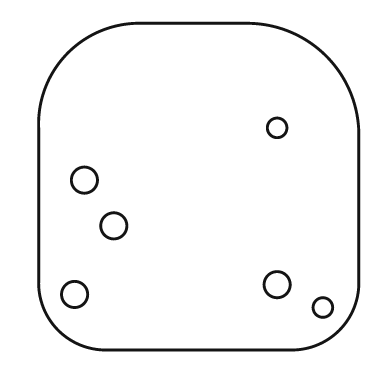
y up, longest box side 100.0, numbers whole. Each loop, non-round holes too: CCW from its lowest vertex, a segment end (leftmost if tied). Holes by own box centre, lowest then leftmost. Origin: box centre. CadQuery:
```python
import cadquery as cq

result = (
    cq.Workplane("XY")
    .moveTo(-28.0, -50.0)
    .lineTo(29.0, -50.0)
    .threePointArc((43.0, -44.0), (49.0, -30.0))
    .lineTo(49.0, 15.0)
    .threePointArc((39.0, 40.0), (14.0, 50.0))
    .lineTo(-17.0, 50.0)
    .threePointArc((-40.0, 41.0), (-49.0, 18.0))
    .lineTo(-49.0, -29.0)
    .threePointArc((-43.0, -44.0), (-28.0, -50.0))
    .close()
    .moveTo(38.0, -37.0)
    .circle(3.0)
    .moveTo(-38.0, -33.0)
    .circle(4.0)
    .moveTo(24.0, -30.0)
    .circle(4.0)
    .moveTo(-26.0, -12.0)
    .circle(4.0)
    .moveTo(-35.0, 2.0)
    .circle(4.0)
    .moveTo(24.0, 18.0)
    .circle(3.0)
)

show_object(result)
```